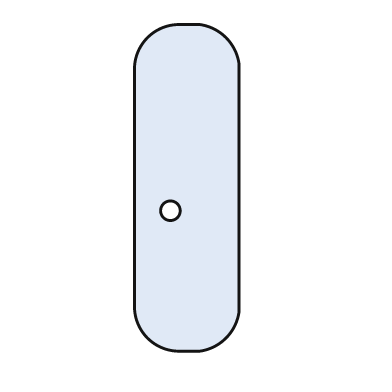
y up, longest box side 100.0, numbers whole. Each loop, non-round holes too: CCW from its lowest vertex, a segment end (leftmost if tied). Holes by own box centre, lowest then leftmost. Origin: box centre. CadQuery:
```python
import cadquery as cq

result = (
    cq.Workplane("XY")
    .moveTo(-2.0, -50.0)
    .lineTo(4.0, -50.0)
    .threePointArc((12.0, -46.0), (16.0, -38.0))
    .lineTo(16.0, 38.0)
    .threePointArc((12.0, 46.0), (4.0, 50.0))
    .lineTo(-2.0, 50.0)
    .threePointArc((-12.0, 46.0), (-16.0, 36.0))
    .lineTo(-16.0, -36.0)
    .threePointArc((-12.0, -46.0), (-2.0, -50.0))
    .close()
    .moveTo(-5.0, -7.0)
    .circle(3.0)
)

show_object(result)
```